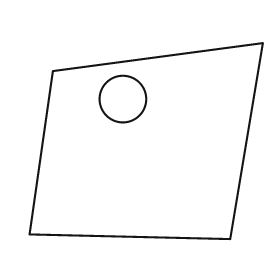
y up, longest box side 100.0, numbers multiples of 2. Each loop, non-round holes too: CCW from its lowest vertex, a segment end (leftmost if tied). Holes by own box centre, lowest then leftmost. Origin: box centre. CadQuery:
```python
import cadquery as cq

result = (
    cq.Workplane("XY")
    .moveTo(36.0, -42.0)
    .lineTo(50.0, 42.0)
    .lineTo(-40.0, 30.0)
    .lineTo(-50.0, -40.0)
    .close()
    .moveTo(-10.0, 18.0)
    .circle(10.0)
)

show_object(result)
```